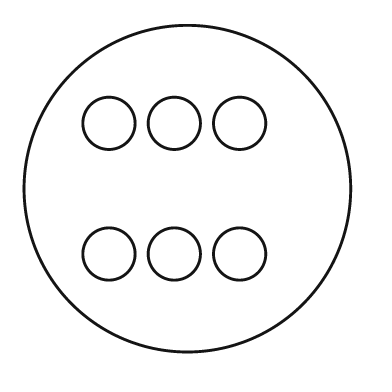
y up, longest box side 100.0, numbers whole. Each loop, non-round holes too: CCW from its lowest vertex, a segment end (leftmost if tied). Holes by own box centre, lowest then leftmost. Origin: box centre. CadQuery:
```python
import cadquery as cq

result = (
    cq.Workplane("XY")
    .moveTo(0.0, 0.0)
    .circle(50.0)
    .moveTo(-24.0, -20.0)
    .circle(8.0)
    .moveTo(-4.0, -20.0)
    .circle(8.0)
    .moveTo(16.0, -20.0)
    .circle(8.0)
    .moveTo(-24.0, 20.0)
    .circle(8.0)
    .moveTo(-4.0, 20.0)
    .circle(8.0)
    .moveTo(16.0, 20.0)
    .circle(8.0)
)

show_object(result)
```